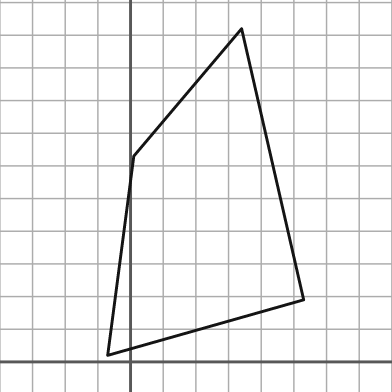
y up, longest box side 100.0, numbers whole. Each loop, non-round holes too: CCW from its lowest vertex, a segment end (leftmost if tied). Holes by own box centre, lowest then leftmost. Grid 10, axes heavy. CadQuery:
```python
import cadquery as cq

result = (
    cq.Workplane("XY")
    .moveTo(-7.0, 2.0)
    .lineTo(53.0, 19.0)
    .lineTo(34.0, 102.0)
    .lineTo(1.0, 63.0)
    .close()
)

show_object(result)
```